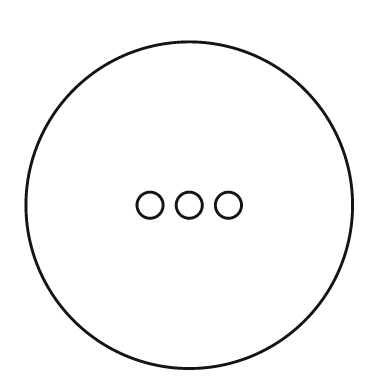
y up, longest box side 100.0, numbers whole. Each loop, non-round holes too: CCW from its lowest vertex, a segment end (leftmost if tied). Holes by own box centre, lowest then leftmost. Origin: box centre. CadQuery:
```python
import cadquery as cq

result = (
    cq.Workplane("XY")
    .moveTo(0.0, 0.0)
    .circle(50.0)
    .moveTo(-12.0, 0.0)
    .circle(4.0)
    .moveTo(0.0, 0.0)
    .circle(4.0)
    .moveTo(12.0, 0.0)
    .circle(4.0)
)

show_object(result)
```